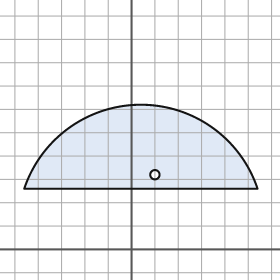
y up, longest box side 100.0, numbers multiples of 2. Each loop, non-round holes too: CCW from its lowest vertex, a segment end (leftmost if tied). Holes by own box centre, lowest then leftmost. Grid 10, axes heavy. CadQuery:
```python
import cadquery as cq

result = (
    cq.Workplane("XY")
    .moveTo(-46.0, 26.0)
    .lineTo(54.0, 26.0)
    .threePointArc((4.0, 62.0), (-46.0, 26.0))
    .close()
    .moveTo(10.0, 32.0)
    .circle(2.0)
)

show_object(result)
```